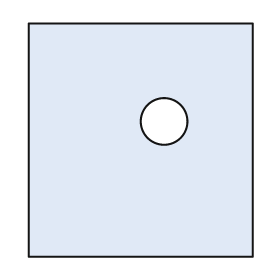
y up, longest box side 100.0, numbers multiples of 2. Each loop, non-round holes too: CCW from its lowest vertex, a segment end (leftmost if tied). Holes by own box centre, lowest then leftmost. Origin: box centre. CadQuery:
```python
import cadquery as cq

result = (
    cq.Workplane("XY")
    .moveTo(-48.0, -50.0)
    .lineTo(48.0, -50.0)
    .lineTo(48.0, 50.0)
    .lineTo(-48.0, 50.0)
    .close()
    .moveTo(10.0, 8.0)
    .circle(10.0)
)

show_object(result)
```